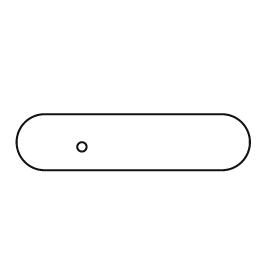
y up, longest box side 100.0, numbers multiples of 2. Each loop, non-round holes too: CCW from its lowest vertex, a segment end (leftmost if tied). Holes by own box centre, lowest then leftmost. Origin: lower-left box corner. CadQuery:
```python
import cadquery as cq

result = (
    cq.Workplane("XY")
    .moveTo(12.0, 0.0)
    .lineTo(88.0, 0.0)
    .threePointArc((100.0, 12.0), (88.0, 24.0))
    .lineTo(12.0, 24.0)
    .threePointArc((0.0, 12.0), (12.0, 0.0))
    .close()
    .moveTo(28.0, 10.0)
    .circle(2.0)
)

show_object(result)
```